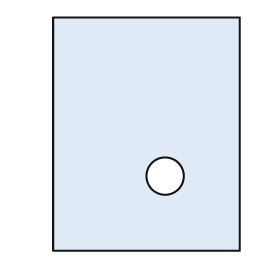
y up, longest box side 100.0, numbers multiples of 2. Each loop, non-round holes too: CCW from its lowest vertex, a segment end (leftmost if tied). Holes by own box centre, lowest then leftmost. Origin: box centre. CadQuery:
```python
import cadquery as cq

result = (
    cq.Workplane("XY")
    .moveTo(-40.0, -50.0)
    .lineTo(40.0, -50.0)
    .lineTo(40.0, 50.0)
    .lineTo(-40.0, 50.0)
    .close()
    .moveTo(8.0, -18.0)
    .circle(8.0)
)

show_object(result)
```